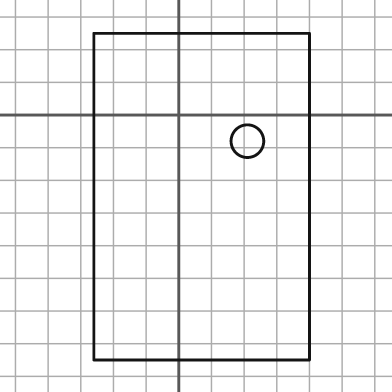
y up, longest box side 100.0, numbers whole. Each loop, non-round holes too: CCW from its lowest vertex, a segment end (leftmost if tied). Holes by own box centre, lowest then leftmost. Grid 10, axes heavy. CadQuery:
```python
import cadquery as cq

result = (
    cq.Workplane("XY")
    .moveTo(-26.0, -75.0)
    .lineTo(40.0, -75.0)
    .lineTo(40.0, 25.0)
    .lineTo(-26.0, 25.0)
    .close()
    .moveTo(21.0, -8.0)
    .circle(5.0)
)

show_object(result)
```